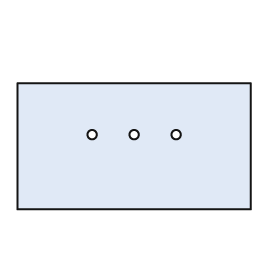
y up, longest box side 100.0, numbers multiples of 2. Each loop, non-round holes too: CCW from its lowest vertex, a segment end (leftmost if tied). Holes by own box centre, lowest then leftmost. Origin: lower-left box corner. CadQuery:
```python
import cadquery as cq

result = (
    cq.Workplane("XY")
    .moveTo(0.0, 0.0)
    .lineTo(100.0, 0.0)
    .lineTo(100.0, 54.0)
    .lineTo(0.0, 54.0)
    .close()
    .moveTo(32.0, 32.0)
    .circle(2.0)
    .moveTo(50.0, 32.0)
    .circle(2.0)
    .moveTo(68.0, 32.0)
    .circle(2.0)
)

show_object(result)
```